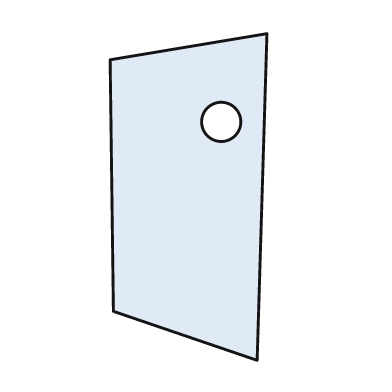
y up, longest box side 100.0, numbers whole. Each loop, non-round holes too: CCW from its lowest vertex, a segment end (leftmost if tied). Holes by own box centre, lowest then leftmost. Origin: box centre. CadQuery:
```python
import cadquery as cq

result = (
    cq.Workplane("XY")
    .moveTo(21.0, -50.0)
    .lineTo(24.0, 50.0)
    .lineTo(-24.0, 42.0)
    .lineTo(-23.0, -35.0)
    .close()
    .moveTo(10.0, 23.0)
    .circle(6.0)
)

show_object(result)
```